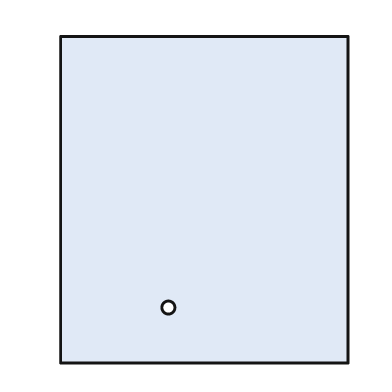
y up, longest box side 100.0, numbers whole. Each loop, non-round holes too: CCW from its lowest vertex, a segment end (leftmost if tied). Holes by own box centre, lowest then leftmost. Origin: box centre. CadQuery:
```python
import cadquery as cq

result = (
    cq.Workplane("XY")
    .moveTo(-44.0, -50.0)
    .lineTo(44.0, -50.0)
    .lineTo(44.0, 50.0)
    .lineTo(-44.0, 50.0)
    .close()
    .moveTo(-11.0, -33.0)
    .circle(2.0)
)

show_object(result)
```